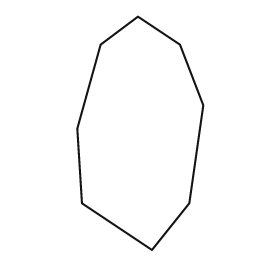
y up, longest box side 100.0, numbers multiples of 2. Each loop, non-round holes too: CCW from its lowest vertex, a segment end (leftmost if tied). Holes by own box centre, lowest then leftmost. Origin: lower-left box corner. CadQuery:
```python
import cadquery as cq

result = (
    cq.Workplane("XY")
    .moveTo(32.0, 0.0)
    .lineTo(48.0, 20.0)
    .lineTo(54.0, 62.0)
    .lineTo(44.0, 88.0)
    .lineTo(26.0, 100.0)
    .lineTo(10.0, 88.0)
    .lineTo(0.0, 52.0)
    .lineTo(2.0, 20.0)
    .close()
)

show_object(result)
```